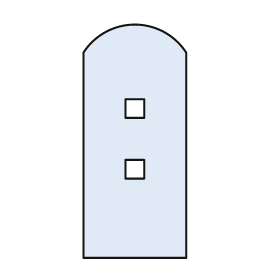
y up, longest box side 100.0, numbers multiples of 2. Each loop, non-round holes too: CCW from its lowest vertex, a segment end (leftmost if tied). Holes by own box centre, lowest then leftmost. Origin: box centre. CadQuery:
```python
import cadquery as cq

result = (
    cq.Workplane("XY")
    .moveTo(-22.0, -50.0)
    .lineTo(22.0, -50.0)
    .lineTo(22.0, 38.0)
    .threePointArc((0.0, 50.0), (-22.0, 38.0))
    .close()
    .moveTo(-4.0, -16.0)
    .lineTo(4.0, -16.0)
    .lineTo(4.0, -8.0)
    .lineTo(-4.0, -8.0)
    .close()
    .moveTo(-4.0, 10.0)
    .lineTo(4.0, 10.0)
    .lineTo(4.0, 18.0)
    .lineTo(-4.0, 18.0)
    .close()
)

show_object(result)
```